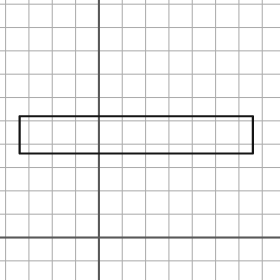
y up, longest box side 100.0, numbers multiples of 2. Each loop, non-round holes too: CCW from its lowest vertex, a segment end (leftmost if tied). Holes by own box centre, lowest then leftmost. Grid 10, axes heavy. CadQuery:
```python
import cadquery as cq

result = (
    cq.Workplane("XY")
    .moveTo(-34.0, 36.0)
    .lineTo(66.0, 36.0)
    .lineTo(66.0, 52.0)
    .lineTo(-34.0, 52.0)
    .close()
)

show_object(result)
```